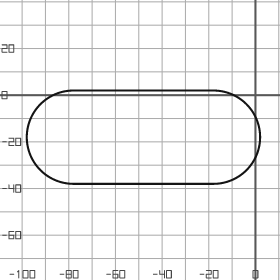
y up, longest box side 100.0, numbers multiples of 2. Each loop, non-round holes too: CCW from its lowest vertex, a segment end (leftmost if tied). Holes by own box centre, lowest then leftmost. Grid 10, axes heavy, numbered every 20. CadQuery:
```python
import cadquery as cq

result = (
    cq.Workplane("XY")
    .moveTo(-78.0, -38.0)
    .lineTo(-18.0, -38.0)
    .threePointArc((2.0, -18.0), (-18.0, 2.0))
    .lineTo(-78.0, 2.0)
    .threePointArc((-98.0, -18.0), (-78.0, -38.0))
    .close()
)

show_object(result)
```